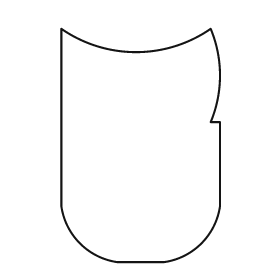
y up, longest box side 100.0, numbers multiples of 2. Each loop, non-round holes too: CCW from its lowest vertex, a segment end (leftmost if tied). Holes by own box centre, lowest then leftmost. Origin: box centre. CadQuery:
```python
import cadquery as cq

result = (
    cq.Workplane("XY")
    .moveTo(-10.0, -50.0)
    .lineTo(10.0, -50.0)
    .threePointArc((26.0, -42.0), (34.0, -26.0))
    .lineTo(34.0, 10.0)
    .lineTo(30.0, 10.0)
    .threePointArc((34.0, 30.0), (30.0, 50.0))
    .threePointArc((-2.0, 40.0), (-34.0, 50.0))
    .lineTo(-34.0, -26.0)
    .threePointArc((-26.0, -42.0), (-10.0, -50.0))
    .close()
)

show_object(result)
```